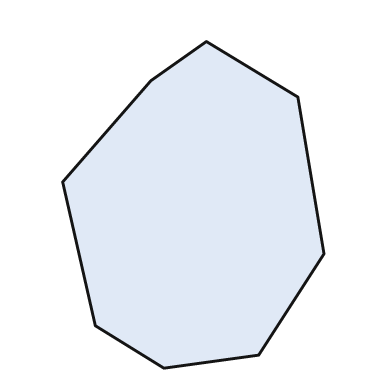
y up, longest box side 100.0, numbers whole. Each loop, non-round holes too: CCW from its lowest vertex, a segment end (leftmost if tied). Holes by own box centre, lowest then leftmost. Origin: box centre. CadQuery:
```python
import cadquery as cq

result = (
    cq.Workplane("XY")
    .moveTo(-9.0, -50.0)
    .lineTo(20.0, -46.0)
    .lineTo(40.0, -15.0)
    .lineTo(32.0, 33.0)
    .lineTo(4.0, 50.0)
    .lineTo(-13.0, 38.0)
    .lineTo(-40.0, 7.0)
    .lineTo(-30.0, -37.0)
    .close()
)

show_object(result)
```